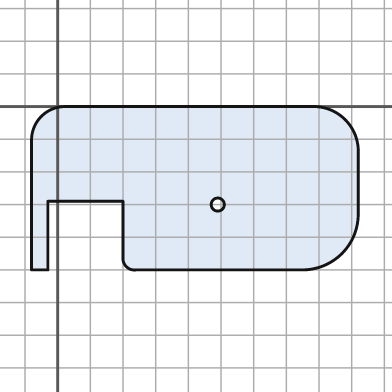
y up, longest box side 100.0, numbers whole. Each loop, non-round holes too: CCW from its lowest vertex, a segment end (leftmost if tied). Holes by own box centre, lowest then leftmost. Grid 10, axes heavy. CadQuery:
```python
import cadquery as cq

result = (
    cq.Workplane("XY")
    .moveTo(-8.0, -50.0)
    .lineTo(-3.0, -50.0)
    .lineTo(-3.0, -29.0)
    .lineTo(20.0, -29.0)
    .lineTo(20.0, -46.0)
    .threePointArc((21.0, -49.0), (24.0, -50.0))
    .lineTo(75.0, -50.0)
    .threePointArc((87.0, -45.0), (92.0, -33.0))
    .lineTo(92.0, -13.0)
    .threePointArc((88.0, -4.0), (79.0, 0.0))
    .lineTo(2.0, 0.0)
    .threePointArc((-5.0, -3.0), (-8.0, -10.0))
    .close()
    .moveTo(49.0, -30.0)
    .circle(2.0)
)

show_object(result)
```